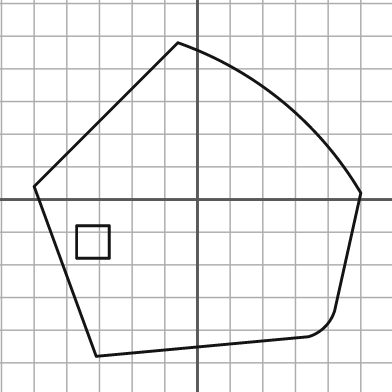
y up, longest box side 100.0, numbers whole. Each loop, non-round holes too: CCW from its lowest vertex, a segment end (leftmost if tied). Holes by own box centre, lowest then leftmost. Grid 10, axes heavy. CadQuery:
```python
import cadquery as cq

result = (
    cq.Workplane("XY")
    .moveTo(-31.0, -48.0)
    .lineTo(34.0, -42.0)
    .threePointArc((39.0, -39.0), (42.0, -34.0))
    .lineTo(50.0, 2.0)
    .threePointArc((26.0, 30.0), (-6.0, 48.0))
    .lineTo(-50.0, 4.0)
    .close()
    .moveTo(-37.0, -18.0)
    .lineTo(-27.0, -18.0)
    .lineTo(-27.0, -8.0)
    .lineTo(-37.0, -8.0)
    .close()
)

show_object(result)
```